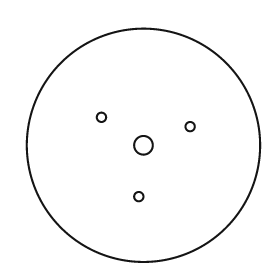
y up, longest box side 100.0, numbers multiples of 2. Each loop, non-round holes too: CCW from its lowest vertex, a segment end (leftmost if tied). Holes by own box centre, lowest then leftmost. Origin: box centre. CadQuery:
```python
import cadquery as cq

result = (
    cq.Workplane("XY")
    .moveTo(0.0, 0.0)
    .circle(50.0)
    .moveTo(-2.0, -22.0)
    .circle(2.0)
    .moveTo(0.0, 0.0)
    .circle(4.0)
    .moveTo(20.0, 8.0)
    .circle(2.0)
    .moveTo(-18.0, 12.0)
    .circle(2.0)
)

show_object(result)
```